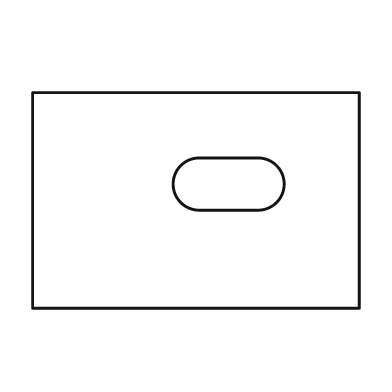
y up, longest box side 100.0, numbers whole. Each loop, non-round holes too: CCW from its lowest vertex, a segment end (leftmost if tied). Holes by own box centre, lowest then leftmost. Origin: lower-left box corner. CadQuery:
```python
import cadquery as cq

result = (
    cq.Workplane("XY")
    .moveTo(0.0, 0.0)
    .lineTo(100.0, 0.0)
    .lineTo(100.0, 66.0)
    .lineTo(0.0, 66.0)
    .close()
    .moveTo(51.0, 30.0)
    .lineTo(69.0, 30.0)
    .threePointArc((77.0, 38.0), (69.0, 46.0))
    .lineTo(51.0, 46.0)
    .threePointArc((43.0, 38.0), (51.0, 30.0))
    .close()
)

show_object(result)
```